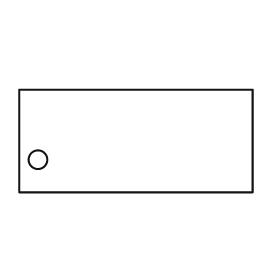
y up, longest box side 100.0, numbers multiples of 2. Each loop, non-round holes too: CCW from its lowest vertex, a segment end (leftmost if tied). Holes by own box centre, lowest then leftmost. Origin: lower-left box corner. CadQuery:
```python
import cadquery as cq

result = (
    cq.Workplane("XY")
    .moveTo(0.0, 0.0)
    .lineTo(100.0, 0.0)
    .lineTo(100.0, 44.0)
    .lineTo(0.0, 44.0)
    .close()
    .moveTo(8.0, 14.0)
    .circle(4.0)
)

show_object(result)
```